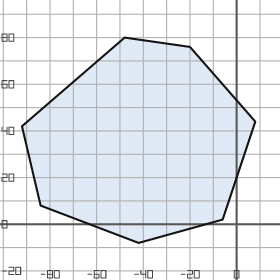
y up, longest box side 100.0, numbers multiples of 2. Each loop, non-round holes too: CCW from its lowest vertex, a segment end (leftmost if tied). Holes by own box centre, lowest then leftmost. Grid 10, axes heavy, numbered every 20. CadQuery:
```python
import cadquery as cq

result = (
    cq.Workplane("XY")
    .moveTo(-42.0, -8.0)
    .lineTo(-6.0, 2.0)
    .lineTo(8.0, 44.0)
    .lineTo(-20.0, 76.0)
    .lineTo(-48.0, 80.0)
    .lineTo(-92.0, 42.0)
    .lineTo(-84.0, 8.0)
    .close()
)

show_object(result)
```